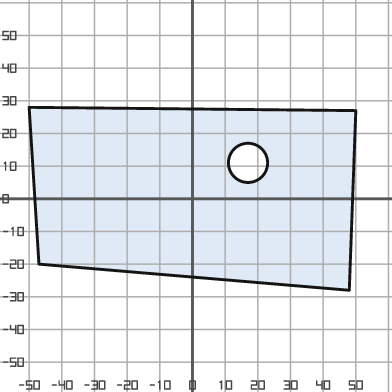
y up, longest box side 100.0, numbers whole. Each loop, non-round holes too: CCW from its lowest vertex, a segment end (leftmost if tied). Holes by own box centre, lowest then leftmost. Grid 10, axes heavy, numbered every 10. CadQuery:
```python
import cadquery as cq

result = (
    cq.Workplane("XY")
    .moveTo(48.0, -28.0)
    .lineTo(50.0, 27.0)
    .lineTo(-50.0, 28.0)
    .lineTo(-47.0, -20.0)
    .close()
    .moveTo(17.0, 11.0)
    .circle(6.0)
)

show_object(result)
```